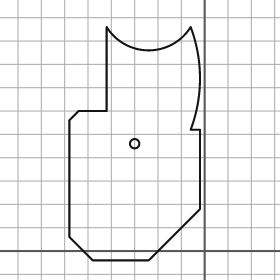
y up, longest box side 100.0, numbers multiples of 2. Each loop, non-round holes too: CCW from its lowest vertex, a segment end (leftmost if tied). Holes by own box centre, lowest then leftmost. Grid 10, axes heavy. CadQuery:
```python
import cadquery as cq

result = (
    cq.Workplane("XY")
    .moveTo(-48.0, -4.0)
    .lineTo(-24.0, -4.0)
    .lineTo(-2.0, 18.0)
    .lineTo(-2.0, 52.0)
    .lineTo(-6.0, 52.0)
    .threePointArc((-2.0, 74.0), (-6.0, 96.0))
    .threePointArc((-24.0, 86.0), (-42.0, 96.0))
    .lineTo(-42.0, 60.0)
    .lineTo(-54.0, 60.0)
    .lineTo(-58.0, 56.0)
    .lineTo(-58.0, 6.0)
    .close()
    .moveTo(-30.0, 46.0)
    .circle(2.0)
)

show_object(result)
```